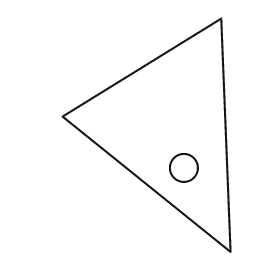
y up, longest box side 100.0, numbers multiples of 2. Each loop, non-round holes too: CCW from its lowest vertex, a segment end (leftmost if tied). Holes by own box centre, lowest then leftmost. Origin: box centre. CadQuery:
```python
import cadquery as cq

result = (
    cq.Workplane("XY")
    .moveTo(36.0, -50.0)
    .lineTo(32.0, 50.0)
    .lineTo(-36.0, 8.0)
    .close()
    .moveTo(16.0, -14.0)
    .circle(6.0)
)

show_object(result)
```